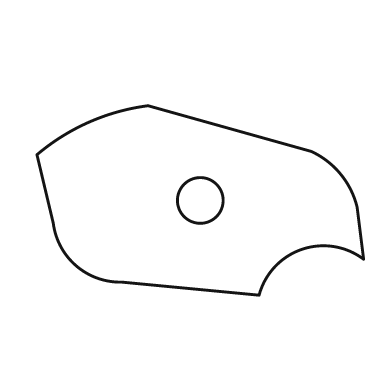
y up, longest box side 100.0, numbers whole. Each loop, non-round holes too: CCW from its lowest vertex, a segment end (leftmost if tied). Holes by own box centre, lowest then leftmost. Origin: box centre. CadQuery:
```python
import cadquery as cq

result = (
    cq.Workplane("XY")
    .moveTo(18.0, -29.0)
    .threePointArc((31.0, -15.0), (50.0, -18.0))
    .lineTo(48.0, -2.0)
    .threePointArc((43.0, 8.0), (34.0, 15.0))
    .lineTo(-16.0, 29.0)
    .threePointArc((-34.0, 24.0), (-50.0, 14.0))
    .lineTo(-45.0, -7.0)
    .threePointArc((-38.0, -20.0), (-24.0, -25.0))
    .close()
    .moveTo(0.0, 0.0)
    .circle(7.0)
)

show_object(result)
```